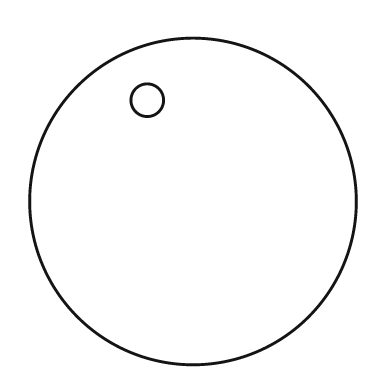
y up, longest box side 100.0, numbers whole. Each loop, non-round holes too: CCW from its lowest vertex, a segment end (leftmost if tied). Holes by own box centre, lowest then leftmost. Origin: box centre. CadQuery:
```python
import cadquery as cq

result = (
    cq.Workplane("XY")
    .moveTo(0.0, 0.0)
    .circle(50.0)
    .moveTo(-14.0, 31.0)
    .circle(5.0)
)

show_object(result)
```